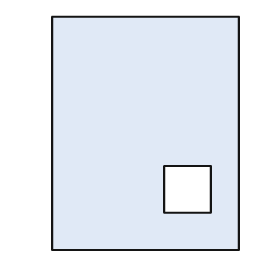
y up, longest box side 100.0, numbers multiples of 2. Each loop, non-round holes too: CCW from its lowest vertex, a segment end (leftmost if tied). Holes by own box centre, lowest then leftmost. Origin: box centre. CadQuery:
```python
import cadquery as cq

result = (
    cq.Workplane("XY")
    .moveTo(-40.0, -50.0)
    .lineTo(40.0, -50.0)
    .lineTo(40.0, 50.0)
    .lineTo(-40.0, 50.0)
    .close()
    .moveTo(8.0, -34.0)
    .lineTo(28.0, -34.0)
    .lineTo(28.0, -14.0)
    .lineTo(8.0, -14.0)
    .close()
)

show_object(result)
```